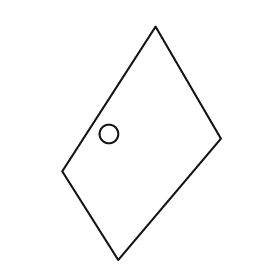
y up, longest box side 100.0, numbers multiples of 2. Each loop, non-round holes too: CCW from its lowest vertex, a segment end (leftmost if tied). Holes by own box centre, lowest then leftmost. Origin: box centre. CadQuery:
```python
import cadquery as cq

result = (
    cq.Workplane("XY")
    .moveTo(-10.0, -50.0)
    .lineTo(34.0, 2.0)
    .lineTo(6.0, 50.0)
    .lineTo(-34.0, -12.0)
    .close()
    .moveTo(-14.0, 4.0)
    .circle(4.0)
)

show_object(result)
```